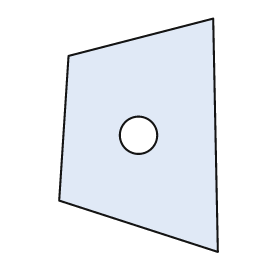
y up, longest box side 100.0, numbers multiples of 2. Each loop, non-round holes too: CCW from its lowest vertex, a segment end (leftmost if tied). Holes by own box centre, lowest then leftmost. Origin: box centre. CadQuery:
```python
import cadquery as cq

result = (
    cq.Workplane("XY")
    .moveTo(34.0, -50.0)
    .lineTo(32.0, 50.0)
    .lineTo(-30.0, 34.0)
    .lineTo(-34.0, -28.0)
    .close()
    .moveTo(0.0, 0.0)
    .circle(8.0)
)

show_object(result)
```